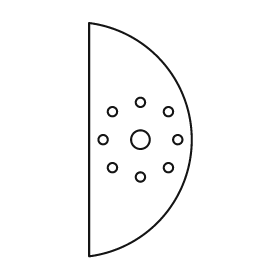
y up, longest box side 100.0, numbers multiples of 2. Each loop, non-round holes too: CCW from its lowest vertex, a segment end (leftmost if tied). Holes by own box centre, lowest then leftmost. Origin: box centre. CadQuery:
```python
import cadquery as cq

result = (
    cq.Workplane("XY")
    .moveTo(-22.0, -50.0)
    .threePointArc((22.0, 0.0), (-22.0, 50.0))
    .close()
    .moveTo(0.0, -16.0)
    .circle(2.0)
    .moveTo(-12.0, -12.0)
    .circle(2.0)
    .moveTo(12.0, -12.0)
    .circle(2.0)
    .moveTo(-16.0, 0.0)
    .circle(2.0)
    .moveTo(0.0, 0.0)
    .circle(4.0)
    .moveTo(16.0, 0.0)
    .circle(2.0)
    .moveTo(-12.0, 12.0)
    .circle(2.0)
    .moveTo(12.0, 12.0)
    .circle(2.0)
    .moveTo(0.0, 16.0)
    .circle(2.0)
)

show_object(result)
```